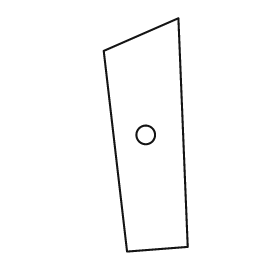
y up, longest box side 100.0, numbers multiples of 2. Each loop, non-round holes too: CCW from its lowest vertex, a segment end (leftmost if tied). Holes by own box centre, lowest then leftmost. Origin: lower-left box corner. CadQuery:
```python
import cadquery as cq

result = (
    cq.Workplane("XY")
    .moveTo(10.0, 0.0)
    .lineTo(36.0, 2.0)
    .lineTo(32.0, 100.0)
    .lineTo(0.0, 86.0)
    .close()
    .moveTo(18.0, 50.0)
    .circle(4.0)
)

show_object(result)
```